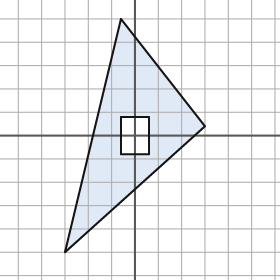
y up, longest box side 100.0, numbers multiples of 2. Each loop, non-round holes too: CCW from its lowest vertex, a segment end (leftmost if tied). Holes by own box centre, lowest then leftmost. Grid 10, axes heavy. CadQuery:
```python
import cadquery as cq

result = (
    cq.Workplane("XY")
    .moveTo(-30.0, -50.0)
    .lineTo(30.0, 4.0)
    .lineTo(-6.0, 50.0)
    .close()
    .moveTo(-6.0, -8.0)
    .lineTo(6.0, -8.0)
    .lineTo(6.0, 8.0)
    .lineTo(-6.0, 8.0)
    .close()
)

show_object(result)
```